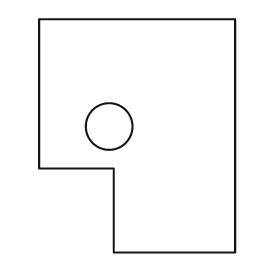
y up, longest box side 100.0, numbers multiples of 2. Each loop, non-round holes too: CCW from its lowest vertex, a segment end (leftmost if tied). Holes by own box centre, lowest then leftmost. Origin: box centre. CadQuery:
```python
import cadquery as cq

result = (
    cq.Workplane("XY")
    .moveTo(-10.0, -50.0)
    .lineTo(42.0, -50.0)
    .lineTo(42.0, 50.0)
    .lineTo(-42.0, 50.0)
    .lineTo(-42.0, -14.0)
    .lineTo(-10.0, -14.0)
    .close()
    .moveTo(-12.0, 4.0)
    .circle(10.0)
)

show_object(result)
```